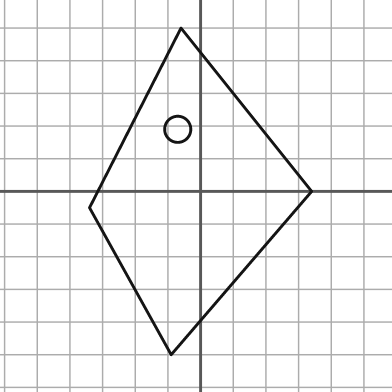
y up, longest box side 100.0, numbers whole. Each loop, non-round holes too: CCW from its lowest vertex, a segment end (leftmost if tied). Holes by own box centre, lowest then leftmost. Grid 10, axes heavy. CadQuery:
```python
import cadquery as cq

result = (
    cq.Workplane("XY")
    .moveTo(-9.0, -50.0)
    .lineTo(34.0, 0.0)
    .lineTo(-6.0, 50.0)
    .lineTo(-34.0, -5.0)
    .close()
    .moveTo(-7.0, 19.0)
    .circle(4.0)
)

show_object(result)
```